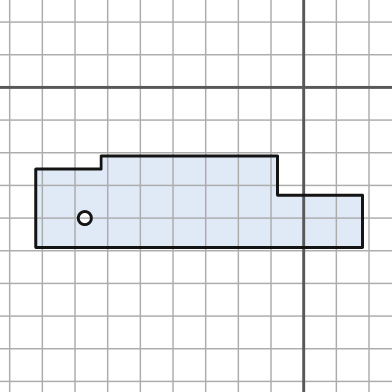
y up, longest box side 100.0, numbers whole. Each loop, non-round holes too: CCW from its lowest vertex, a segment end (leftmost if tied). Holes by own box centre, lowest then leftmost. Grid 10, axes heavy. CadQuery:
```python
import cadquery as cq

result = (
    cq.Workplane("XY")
    .moveTo(-82.0, -49.0)
    .lineTo(18.0, -49.0)
    .lineTo(18.0, -33.0)
    .lineTo(-8.0, -33.0)
    .lineTo(-8.0, -21.0)
    .lineTo(-62.0, -21.0)
    .lineTo(-62.0, -25.0)
    .lineTo(-82.0, -25.0)
    .close()
    .moveTo(-67.0, -40.0)
    .circle(2.0)
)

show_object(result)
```